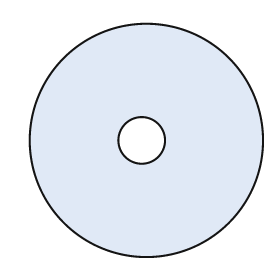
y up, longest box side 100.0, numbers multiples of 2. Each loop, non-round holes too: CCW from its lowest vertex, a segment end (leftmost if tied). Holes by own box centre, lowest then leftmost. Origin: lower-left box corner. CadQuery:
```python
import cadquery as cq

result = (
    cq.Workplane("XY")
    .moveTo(50.0, 50.0)
    .circle(50.0)
    .moveTo(48.0, 50.0)
    .circle(10.0)
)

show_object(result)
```